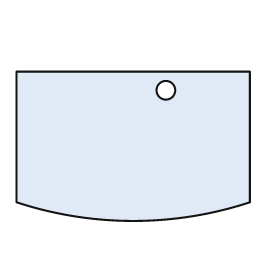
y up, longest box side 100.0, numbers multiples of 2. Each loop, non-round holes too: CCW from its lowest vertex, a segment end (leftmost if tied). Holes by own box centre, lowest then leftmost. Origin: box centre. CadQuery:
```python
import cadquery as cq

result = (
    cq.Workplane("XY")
    .moveTo(-50.0, -24.0)
    .threePointArc((0.0, -32.0), (50.0, -24.0))
    .lineTo(50.0, 32.0)
    .lineTo(-50.0, 32.0)
    .close()
    .moveTo(14.0, 24.0)
    .circle(4.0)
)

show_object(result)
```